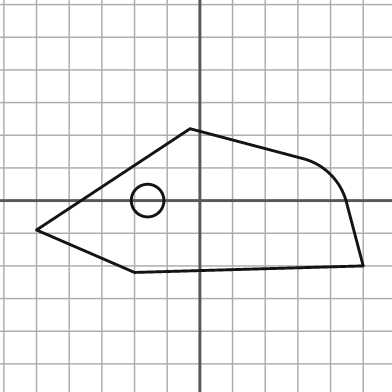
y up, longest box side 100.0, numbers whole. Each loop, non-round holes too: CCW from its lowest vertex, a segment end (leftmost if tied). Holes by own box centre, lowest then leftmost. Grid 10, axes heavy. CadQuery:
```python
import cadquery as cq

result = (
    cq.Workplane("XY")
    .moveTo(-20.0, -22.0)
    .lineTo(50.0, -20.0)
    .lineTo(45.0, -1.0)
    .threePointArc((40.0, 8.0), (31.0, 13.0))
    .lineTo(-3.0, 22.0)
    .lineTo(-50.0, -9.0)
    .close()
    .moveTo(-16.0, 0.0)
    .circle(5.0)
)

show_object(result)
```